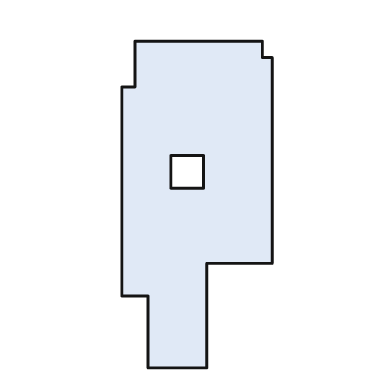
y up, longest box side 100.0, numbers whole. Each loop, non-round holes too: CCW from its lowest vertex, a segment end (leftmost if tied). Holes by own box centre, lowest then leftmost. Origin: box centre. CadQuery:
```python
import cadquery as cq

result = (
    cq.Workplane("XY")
    .moveTo(-15.0, -50.0)
    .lineTo(3.0, -50.0)
    .lineTo(3.0, -18.0)
    .lineTo(23.0, -18.0)
    .lineTo(23.0, 45.0)
    .lineTo(20.0, 45.0)
    .lineTo(20.0, 50.0)
    .lineTo(-19.0, 50.0)
    .lineTo(-19.0, 36.0)
    .lineTo(-23.0, 36.0)
    .lineTo(-23.0, -28.0)
    .lineTo(-15.0, -28.0)
    .close()
    .moveTo(-8.0, 5.0)
    .lineTo(2.0, 5.0)
    .lineTo(2.0, 15.0)
    .lineTo(-8.0, 15.0)
    .close()
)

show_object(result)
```